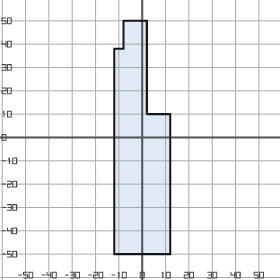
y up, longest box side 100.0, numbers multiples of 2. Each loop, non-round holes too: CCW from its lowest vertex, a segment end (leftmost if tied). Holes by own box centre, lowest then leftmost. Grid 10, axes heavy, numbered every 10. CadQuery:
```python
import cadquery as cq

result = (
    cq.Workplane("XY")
    .moveTo(-12.0, -50.0)
    .lineTo(12.0, -50.0)
    .lineTo(12.0, 10.0)
    .lineTo(2.0, 10.0)
    .lineTo(2.0, 50.0)
    .lineTo(-8.0, 50.0)
    .lineTo(-8.0, 38.0)
    .lineTo(-12.0, 38.0)
    .close()
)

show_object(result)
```